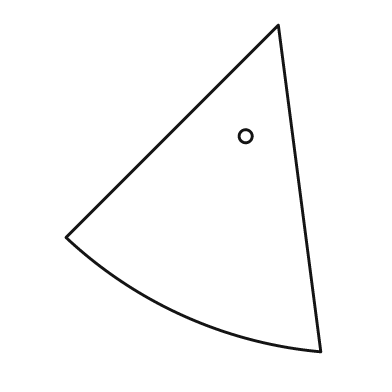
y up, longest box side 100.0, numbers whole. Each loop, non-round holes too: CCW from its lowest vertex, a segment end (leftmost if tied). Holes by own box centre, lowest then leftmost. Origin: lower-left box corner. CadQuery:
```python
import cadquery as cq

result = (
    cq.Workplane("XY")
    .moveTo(78.0, 0.0)
    .lineTo(65.0, 100.0)
    .lineTo(0.0, 35.0)
    .threePointArc((36.0, 11.0), (78.0, 0.0))
    .close()
    .moveTo(55.0, 66.0)
    .circle(2.0)
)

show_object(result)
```